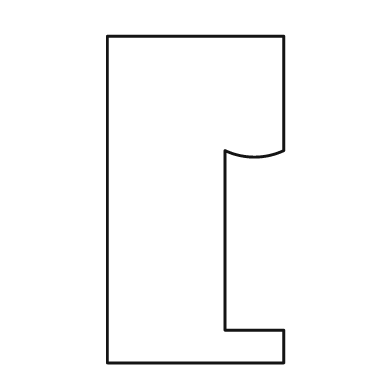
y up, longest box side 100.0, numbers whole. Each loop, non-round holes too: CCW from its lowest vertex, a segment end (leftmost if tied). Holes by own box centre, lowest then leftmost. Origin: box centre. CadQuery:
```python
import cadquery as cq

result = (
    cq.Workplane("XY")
    .moveTo(-27.0, -50.0)
    .lineTo(27.0, -50.0)
    .lineTo(27.0, -40.0)
    .lineTo(9.0, -40.0)
    .lineTo(9.0, 15.0)
    .threePointArc((18.0, 13.0), (27.0, 15.0))
    .lineTo(27.0, 50.0)
    .lineTo(-27.0, 50.0)
    .close()
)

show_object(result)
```